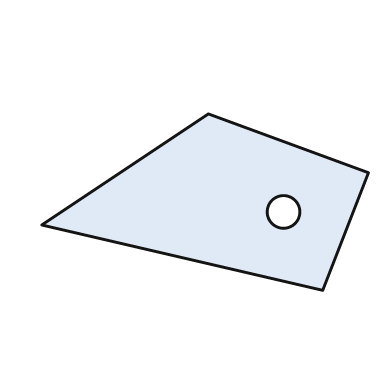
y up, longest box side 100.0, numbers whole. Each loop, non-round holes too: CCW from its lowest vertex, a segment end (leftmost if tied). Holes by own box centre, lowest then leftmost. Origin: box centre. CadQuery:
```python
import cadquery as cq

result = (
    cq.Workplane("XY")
    .moveTo(36.0, -27.0)
    .lineTo(50.0, 9.0)
    .lineTo(1.0, 27.0)
    .lineTo(-50.0, -7.0)
    .close()
    .moveTo(24.0, -3.0)
    .circle(5.0)
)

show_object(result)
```